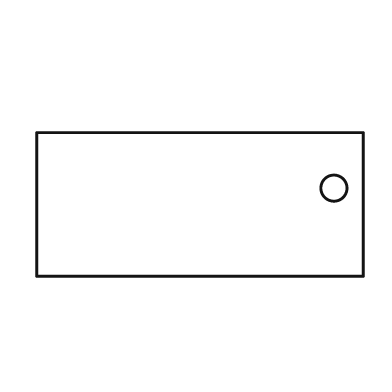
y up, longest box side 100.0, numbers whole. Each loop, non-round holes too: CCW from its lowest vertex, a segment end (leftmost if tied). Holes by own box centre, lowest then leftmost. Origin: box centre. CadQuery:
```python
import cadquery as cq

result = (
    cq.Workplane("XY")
    .moveTo(-50.0, -22.0)
    .lineTo(50.0, -22.0)
    .lineTo(50.0, 22.0)
    .lineTo(-50.0, 22.0)
    .close()
    .moveTo(41.0, 5.0)
    .circle(4.0)
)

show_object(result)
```